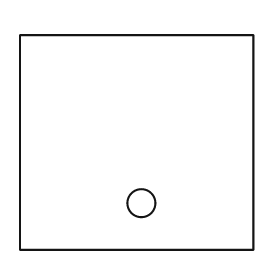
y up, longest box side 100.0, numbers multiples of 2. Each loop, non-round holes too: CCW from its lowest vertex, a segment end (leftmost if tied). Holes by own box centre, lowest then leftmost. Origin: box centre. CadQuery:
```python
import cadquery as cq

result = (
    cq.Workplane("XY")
    .moveTo(-50.0, -46.0)
    .lineTo(50.0, -46.0)
    .lineTo(50.0, 46.0)
    .lineTo(-50.0, 46.0)
    .close()
    .moveTo(2.0, -26.0)
    .circle(6.0)
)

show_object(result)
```